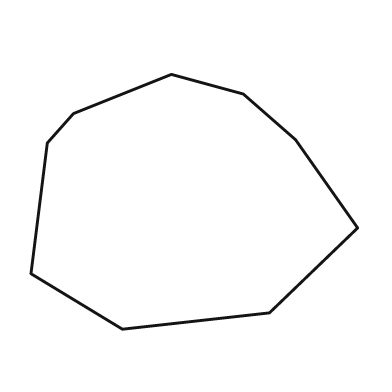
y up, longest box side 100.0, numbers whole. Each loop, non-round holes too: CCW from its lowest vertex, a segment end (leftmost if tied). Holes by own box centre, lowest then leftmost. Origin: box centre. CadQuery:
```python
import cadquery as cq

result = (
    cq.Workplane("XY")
    .moveTo(-22.0, -39.0)
    .lineTo(23.0, -34.0)
    .lineTo(50.0, -8.0)
    .lineTo(31.0, 19.0)
    .lineTo(15.0, 33.0)
    .lineTo(-7.0, 39.0)
    .lineTo(-37.0, 27.0)
    .lineTo(-45.0, 18.0)
    .lineTo(-50.0, -22.0)
    .close()
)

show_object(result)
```